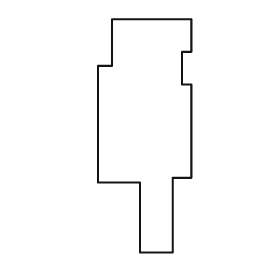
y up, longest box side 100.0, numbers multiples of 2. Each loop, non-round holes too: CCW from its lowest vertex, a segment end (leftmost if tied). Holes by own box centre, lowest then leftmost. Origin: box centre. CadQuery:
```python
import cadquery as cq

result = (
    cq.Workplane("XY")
    .moveTo(-2.0, -50.0)
    .lineTo(12.0, -50.0)
    .lineTo(12.0, -18.0)
    .lineTo(20.0, -18.0)
    .lineTo(20.0, 22.0)
    .lineTo(16.0, 22.0)
    .lineTo(16.0, 36.0)
    .lineTo(20.0, 36.0)
    .lineTo(20.0, 50.0)
    .lineTo(-14.0, 50.0)
    .lineTo(-14.0, 30.0)
    .lineTo(-20.0, 30.0)
    .lineTo(-20.0, -20.0)
    .lineTo(-2.0, -20.0)
    .close()
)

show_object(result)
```